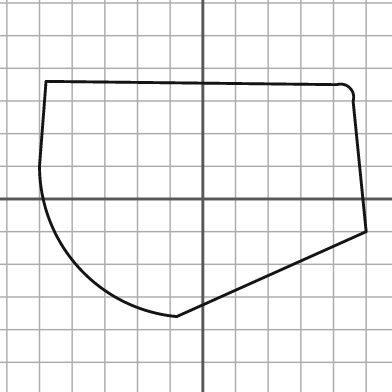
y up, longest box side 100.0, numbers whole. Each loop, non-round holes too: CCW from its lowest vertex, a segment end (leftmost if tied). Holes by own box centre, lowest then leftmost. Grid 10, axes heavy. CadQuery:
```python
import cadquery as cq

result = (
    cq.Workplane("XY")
    .moveTo(-8.0, -36.0)
    .lineTo(50.0, -10.0)
    .lineTo(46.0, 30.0)
    .threePointArc((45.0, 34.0), (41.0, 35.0))
    .lineTo(-48.0, 36.0)
    .lineTo(-50.0, 10.0)
    .threePointArc((-38.0, -21.0), (-8.0, -36.0))
    .close()
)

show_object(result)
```